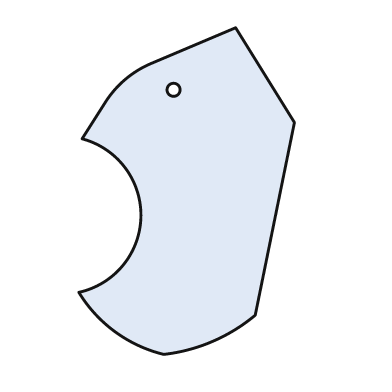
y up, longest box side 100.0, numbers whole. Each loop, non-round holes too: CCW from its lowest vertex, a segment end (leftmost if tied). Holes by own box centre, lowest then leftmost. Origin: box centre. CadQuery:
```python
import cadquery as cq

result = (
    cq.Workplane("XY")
    .moveTo(-7.0, -50.0)
    .threePointArc((8.0, -46.0), (21.0, -38.0))
    .lineTo(33.0, 21.0)
    .lineTo(15.0, 50.0)
    .lineTo(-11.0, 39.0)
    .threePointArc((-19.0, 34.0), (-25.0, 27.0))
    .lineTo(-32.0, 16.0)
    .threePointArc((-14.0, -8.0), (-33.0, -31.0))
    .threePointArc((-22.0, -43.0), (-7.0, -50.0))
    .close()
    .moveTo(-4.0, 31.0)
    .circle(2.0)
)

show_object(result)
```